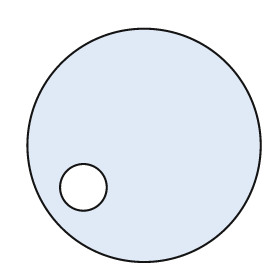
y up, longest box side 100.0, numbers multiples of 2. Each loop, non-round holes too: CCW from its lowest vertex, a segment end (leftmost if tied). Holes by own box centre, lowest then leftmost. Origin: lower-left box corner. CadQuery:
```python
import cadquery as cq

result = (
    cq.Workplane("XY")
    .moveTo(50.0, 50.0)
    .circle(50.0)
    .moveTo(24.0, 32.0)
    .circle(10.0)
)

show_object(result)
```